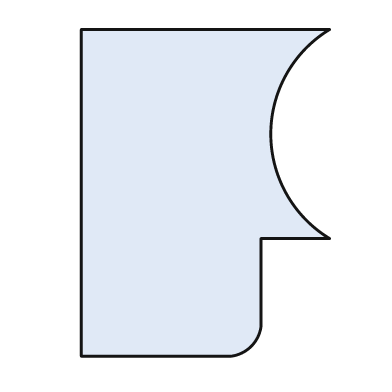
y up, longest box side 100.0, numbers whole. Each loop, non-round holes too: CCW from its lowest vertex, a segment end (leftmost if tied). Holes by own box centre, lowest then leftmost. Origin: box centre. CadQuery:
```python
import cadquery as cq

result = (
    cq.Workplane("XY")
    .moveTo(-38.0, -50.0)
    .lineTo(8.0, -50.0)
    .threePointArc((14.0, -47.0), (17.0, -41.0))
    .lineTo(17.0, -14.0)
    .lineTo(38.0, -14.0)
    .threePointArc((20.0, 18.0), (38.0, 50.0))
    .lineTo(-38.0, 50.0)
    .close()
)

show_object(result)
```